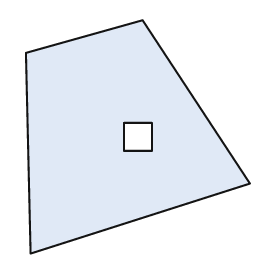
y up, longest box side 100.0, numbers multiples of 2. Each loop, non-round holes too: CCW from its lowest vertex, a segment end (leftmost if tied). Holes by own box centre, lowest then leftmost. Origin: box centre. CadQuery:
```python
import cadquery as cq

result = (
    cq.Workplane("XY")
    .moveTo(-46.0, -50.0)
    .lineTo(48.0, -20.0)
    .lineTo(2.0, 50.0)
    .lineTo(-48.0, 36.0)
    .close()
    .moveTo(-6.0, -6.0)
    .lineTo(6.0, -6.0)
    .lineTo(6.0, 6.0)
    .lineTo(-6.0, 6.0)
    .close()
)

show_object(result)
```